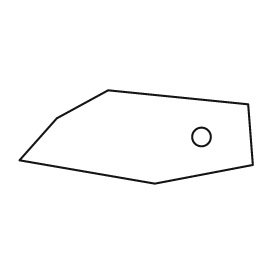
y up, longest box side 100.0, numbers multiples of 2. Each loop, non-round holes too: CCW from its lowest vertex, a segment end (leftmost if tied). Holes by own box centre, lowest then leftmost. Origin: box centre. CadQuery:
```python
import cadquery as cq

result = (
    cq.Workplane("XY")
    .moveTo(8.0, -20.0)
    .lineTo(50.0, -12.0)
    .lineTo(48.0, 14.0)
    .lineTo(-12.0, 20.0)
    .lineTo(-34.0, 8.0)
    .lineTo(-50.0, -10.0)
    .close()
    .moveTo(28.0, 0.0)
    .circle(4.0)
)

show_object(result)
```